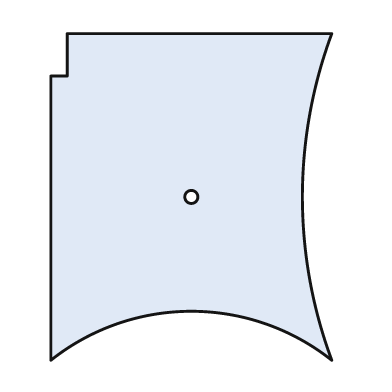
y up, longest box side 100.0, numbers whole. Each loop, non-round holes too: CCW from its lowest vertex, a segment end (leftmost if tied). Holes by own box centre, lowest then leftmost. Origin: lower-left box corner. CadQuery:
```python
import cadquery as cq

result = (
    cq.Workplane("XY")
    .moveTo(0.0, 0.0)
    .threePointArc((43.0, 15.0), (86.0, 0.0))
    .threePointArc((77.0, 50.0), (86.0, 100.0))
    .lineTo(5.0, 100.0)
    .lineTo(5.0, 87.0)
    .lineTo(0.0, 87.0)
    .close()
    .moveTo(43.0, 50.0)
    .circle(2.0)
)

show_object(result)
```